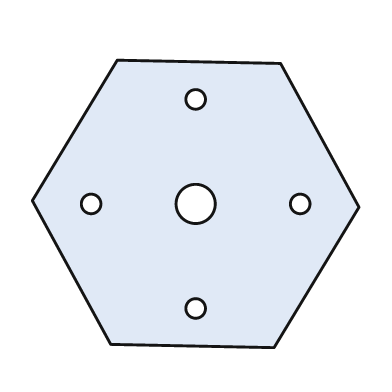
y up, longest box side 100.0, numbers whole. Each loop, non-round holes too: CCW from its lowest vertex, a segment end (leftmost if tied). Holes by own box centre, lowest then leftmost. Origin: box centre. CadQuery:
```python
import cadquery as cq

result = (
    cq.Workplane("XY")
    .moveTo(24.0, -44.0)
    .lineTo(50.0, -1.0)
    .lineTo(26.0, 43.0)
    .lineTo(-24.0, 44.0)
    .lineTo(-50.0, 1.0)
    .lineTo(-26.0, -43.0)
    .close()
    .moveTo(0.0, -32.0)
    .circle(3.0)
    .moveTo(-32.0, 0.0)
    .circle(3.0)
    .moveTo(0.0, 0.0)
    .circle(6.0)
    .moveTo(32.0, 0.0)
    .circle(3.0)
    .moveTo(0.0, 32.0)
    .circle(3.0)
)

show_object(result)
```